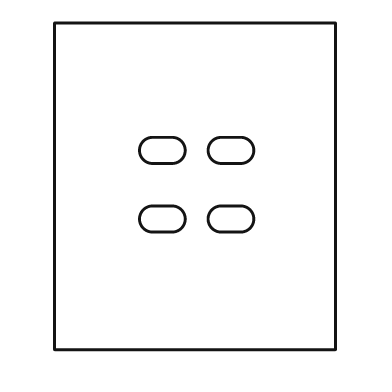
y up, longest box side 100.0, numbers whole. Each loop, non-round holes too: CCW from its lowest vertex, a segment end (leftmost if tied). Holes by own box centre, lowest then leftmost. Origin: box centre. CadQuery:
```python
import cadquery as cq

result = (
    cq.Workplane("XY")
    .moveTo(-43.0, -50.0)
    .lineTo(43.0, -50.0)
    .lineTo(43.0, 50.0)
    .lineTo(-43.0, 50.0)
    .close()
    .moveTo(-13.0, -14.0)
    .lineTo(-7.0, -14.0)
    .threePointArc((-3.0, -10.0), (-7.0, -6.0))
    .lineTo(-13.0, -6.0)
    .threePointArc((-17.0, -10.0), (-13.0, -14.0))
    .close()
    .moveTo(8.0, -14.0)
    .lineTo(14.0, -14.0)
    .threePointArc((18.0, -10.0), (14.0, -6.0))
    .lineTo(8.0, -6.0)
    .threePointArc((4.0, -10.0), (8.0, -14.0))
    .close()
    .moveTo(-13.0, 7.0)
    .lineTo(-7.0, 7.0)
    .threePointArc((-3.0, 11.0), (-7.0, 15.0))
    .lineTo(-13.0, 15.0)
    .threePointArc((-17.0, 11.0), (-13.0, 7.0))
    .close()
    .moveTo(8.0, 7.0)
    .lineTo(14.0, 7.0)
    .threePointArc((18.0, 11.0), (14.0, 15.0))
    .lineTo(8.0, 15.0)
    .threePointArc((4.0, 11.0), (8.0, 7.0))
    .close()
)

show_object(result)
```